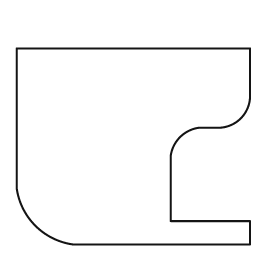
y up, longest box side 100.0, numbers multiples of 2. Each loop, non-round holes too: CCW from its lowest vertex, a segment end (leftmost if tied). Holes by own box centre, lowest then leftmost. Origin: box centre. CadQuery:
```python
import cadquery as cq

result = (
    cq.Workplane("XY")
    .moveTo(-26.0, -42.0)
    .lineTo(50.0, -42.0)
    .lineTo(50.0, -32.0)
    .lineTo(16.0, -32.0)
    .lineTo(16.0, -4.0)
    .threePointArc((20.0, 4.0), (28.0, 8.0))
    .lineTo(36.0, 8.0)
    .threePointArc((46.0, 12.0), (50.0, 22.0))
    .lineTo(50.0, 42.0)
    .lineTo(-50.0, 42.0)
    .lineTo(-50.0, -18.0)
    .threePointArc((-42.0, -34.0), (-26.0, -42.0))
    .close()
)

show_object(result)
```